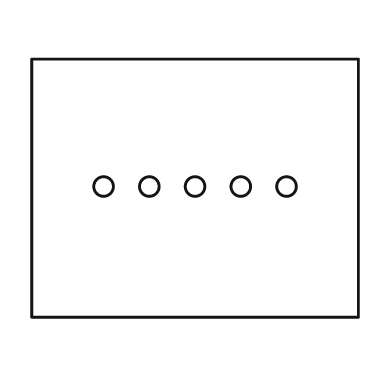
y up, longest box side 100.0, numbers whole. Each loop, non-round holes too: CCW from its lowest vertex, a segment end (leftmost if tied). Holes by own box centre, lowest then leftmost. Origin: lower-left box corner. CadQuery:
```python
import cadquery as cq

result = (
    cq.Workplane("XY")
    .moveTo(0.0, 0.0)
    .lineTo(100.0, 0.0)
    .lineTo(100.0, 79.0)
    .lineTo(0.0, 79.0)
    .close()
    .moveTo(22.0, 40.0)
    .circle(3.0)
    .moveTo(36.0, 40.0)
    .circle(3.0)
    .moveTo(50.0, 40.0)
    .circle(3.0)
    .moveTo(64.0, 40.0)
    .circle(3.0)
    .moveTo(78.0, 40.0)
    .circle(3.0)
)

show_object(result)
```